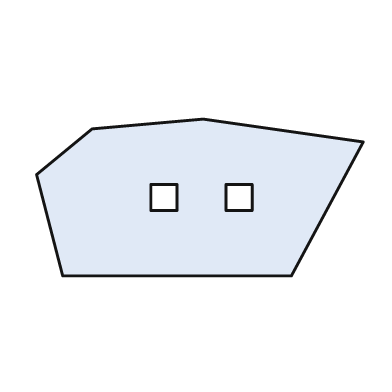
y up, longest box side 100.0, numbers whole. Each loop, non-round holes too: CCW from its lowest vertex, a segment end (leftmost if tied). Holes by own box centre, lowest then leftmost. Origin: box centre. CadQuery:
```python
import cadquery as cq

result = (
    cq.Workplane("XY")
    .moveTo(-42.0, -24.0)
    .lineTo(28.0, -24.0)
    .lineTo(50.0, 17.0)
    .lineTo(1.0, 24.0)
    .lineTo(-33.0, 21.0)
    .lineTo(-50.0, 7.0)
    .close()
    .moveTo(-15.0, -4.0)
    .lineTo(-7.0, -4.0)
    .lineTo(-7.0, 4.0)
    .lineTo(-15.0, 4.0)
    .close()
    .moveTo(8.0, -4.0)
    .lineTo(16.0, -4.0)
    .lineTo(16.0, 4.0)
    .lineTo(8.0, 4.0)
    .close()
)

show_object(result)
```